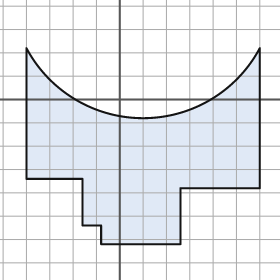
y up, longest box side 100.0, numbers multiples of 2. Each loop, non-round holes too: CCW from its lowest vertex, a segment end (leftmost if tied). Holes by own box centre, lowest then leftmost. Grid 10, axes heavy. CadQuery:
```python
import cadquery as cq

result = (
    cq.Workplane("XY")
    .moveTo(-8.0, -62.0)
    .lineTo(26.0, -62.0)
    .lineTo(26.0, -38.0)
    .lineTo(60.0, -38.0)
    .lineTo(60.0, 22.0)
    .threePointArc((10.0, -8.0), (-40.0, 22.0))
    .lineTo(-40.0, -34.0)
    .lineTo(-16.0, -34.0)
    .lineTo(-16.0, -54.0)
    .lineTo(-8.0, -54.0)
    .close()
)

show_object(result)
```